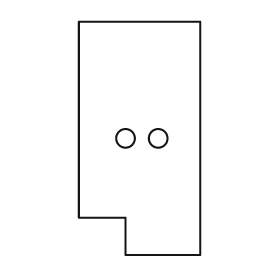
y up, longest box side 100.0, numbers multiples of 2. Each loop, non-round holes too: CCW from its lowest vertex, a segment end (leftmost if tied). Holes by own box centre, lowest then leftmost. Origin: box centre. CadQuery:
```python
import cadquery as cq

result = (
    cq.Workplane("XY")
    .moveTo(-6.0, -50.0)
    .lineTo(26.0, -50.0)
    .lineTo(26.0, 50.0)
    .lineTo(-26.0, 50.0)
    .lineTo(-26.0, -34.0)
    .lineTo(-6.0, -34.0)
    .close()
    .moveTo(-6.0, 0.0)
    .circle(4.0)
    .moveTo(8.0, 0.0)
    .circle(4.0)
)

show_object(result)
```